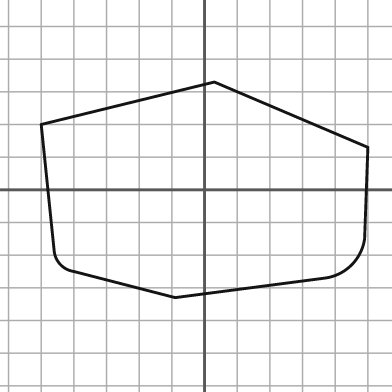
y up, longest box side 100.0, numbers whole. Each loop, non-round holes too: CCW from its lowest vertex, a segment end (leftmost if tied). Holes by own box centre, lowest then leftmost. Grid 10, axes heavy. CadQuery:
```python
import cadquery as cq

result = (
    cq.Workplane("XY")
    .moveTo(-9.0, -33.0)
    .lineTo(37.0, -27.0)
    .threePointArc((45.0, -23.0), (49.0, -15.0))
    .lineTo(50.0, 13.0)
    .lineTo(3.0, 33.0)
    .lineTo(-50.0, 20.0)
    .lineTo(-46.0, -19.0)
    .threePointArc((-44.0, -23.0), (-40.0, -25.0))
    .close()
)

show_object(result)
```